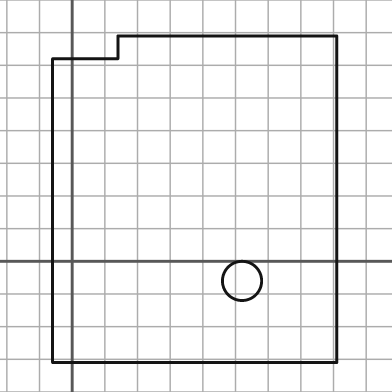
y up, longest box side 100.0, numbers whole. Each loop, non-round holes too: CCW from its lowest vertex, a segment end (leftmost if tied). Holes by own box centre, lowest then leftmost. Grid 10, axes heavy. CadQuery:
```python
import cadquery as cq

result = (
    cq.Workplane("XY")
    .moveTo(-6.0, -31.0)
    .lineTo(81.0, -31.0)
    .lineTo(81.0, 69.0)
    .lineTo(14.0, 69.0)
    .lineTo(14.0, 62.0)
    .lineTo(-6.0, 62.0)
    .close()
    .moveTo(52.0, -6.0)
    .circle(6.0)
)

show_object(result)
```